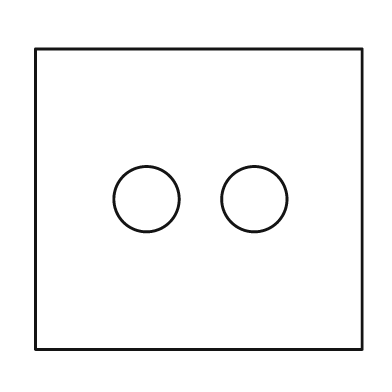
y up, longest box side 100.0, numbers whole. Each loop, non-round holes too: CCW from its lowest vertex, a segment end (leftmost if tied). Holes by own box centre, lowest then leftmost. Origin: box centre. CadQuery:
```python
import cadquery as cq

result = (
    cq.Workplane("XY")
    .moveTo(-50.0, -46.0)
    .lineTo(50.0, -46.0)
    .lineTo(50.0, 46.0)
    .lineTo(-50.0, 46.0)
    .close()
    .moveTo(-16.0, 0.0)
    .circle(10.0)
    .moveTo(17.0, 0.0)
    .circle(10.0)
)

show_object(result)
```